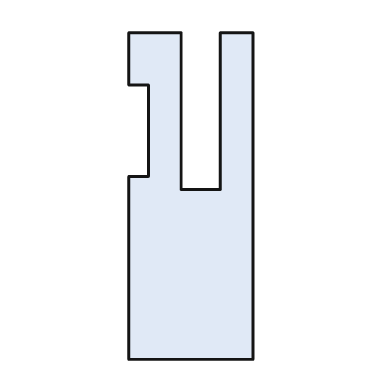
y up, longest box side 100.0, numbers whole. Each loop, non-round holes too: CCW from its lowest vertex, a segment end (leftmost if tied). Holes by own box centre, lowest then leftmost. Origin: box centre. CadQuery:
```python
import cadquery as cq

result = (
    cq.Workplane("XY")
    .moveTo(-19.0, -50.0)
    .lineTo(19.0, -50.0)
    .lineTo(19.0, 50.0)
    .lineTo(9.0, 50.0)
    .lineTo(9.0, 2.0)
    .lineTo(-3.0, 2.0)
    .lineTo(-3.0, 50.0)
    .lineTo(-19.0, 50.0)
    .lineTo(-19.0, 34.0)
    .lineTo(-13.0, 34.0)
    .lineTo(-13.0, 6.0)
    .lineTo(-19.0, 6.0)
    .close()
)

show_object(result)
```